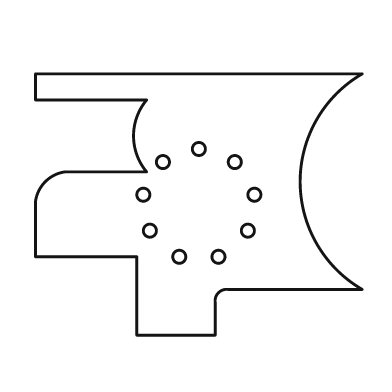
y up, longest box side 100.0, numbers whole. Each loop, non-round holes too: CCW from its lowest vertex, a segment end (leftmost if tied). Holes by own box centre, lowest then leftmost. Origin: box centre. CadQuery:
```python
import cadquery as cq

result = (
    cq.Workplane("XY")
    .moveTo(-19.0, -40.0)
    .lineTo(5.0, -40.0)
    .lineTo(5.0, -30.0)
    .threePointArc((6.0, -27.0), (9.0, -26.0))
    .lineTo(50.0, -26.0)
    .threePointArc((31.0, 7.0), (50.0, 40.0))
    .lineTo(-50.0, 40.0)
    .lineTo(-50.0, 32.0)
    .lineTo(-16.0, 32.0)
    .threePointArc((-20.0, 21.0), (-16.0, 10.0))
    .lineTo(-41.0, 10.0)
    .threePointArc((-47.0, 7.0), (-50.0, 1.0))
    .lineTo(-50.0, -16.0)
    .lineTo(-19.0, -16.0)
    .close()
    .moveTo(-6.0, -16.0)
    .circle(2.0)
    .moveTo(6.0, -16.0)
    .circle(2.0)
    .moveTo(-15.0, -8.0)
    .circle(2.0)
    .moveTo(15.0, -8.0)
    .circle(2.0)
    .moveTo(-17.0, 3.0)
    .circle(2.0)
    .moveTo(17.0, 3.0)
    .circle(2.0)
    .moveTo(-11.0, 13.0)
    .circle(2.0)
    .moveTo(11.0, 13.0)
    .circle(2.0)
    .moveTo(0.0, 17.0)
    .circle(2.0)
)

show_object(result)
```